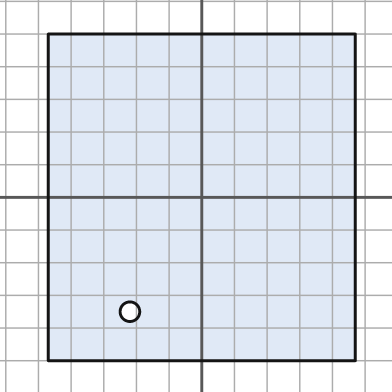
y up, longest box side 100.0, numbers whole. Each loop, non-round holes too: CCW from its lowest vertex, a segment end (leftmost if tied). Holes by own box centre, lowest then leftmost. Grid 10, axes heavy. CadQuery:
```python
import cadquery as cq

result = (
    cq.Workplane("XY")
    .moveTo(-47.0, -50.0)
    .lineTo(47.0, -50.0)
    .lineTo(47.0, 50.0)
    .lineTo(-47.0, 50.0)
    .close()
    .moveTo(-22.0, -35.0)
    .circle(3.0)
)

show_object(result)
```